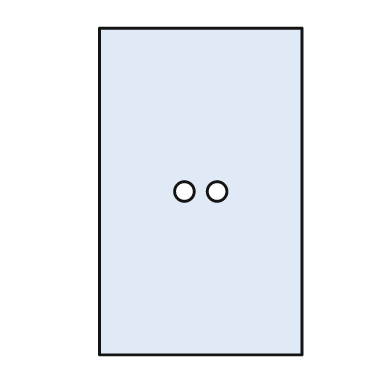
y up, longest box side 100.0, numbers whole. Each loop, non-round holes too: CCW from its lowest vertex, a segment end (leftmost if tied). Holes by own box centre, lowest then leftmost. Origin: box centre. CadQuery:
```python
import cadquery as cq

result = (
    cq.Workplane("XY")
    .moveTo(-31.0, -50.0)
    .lineTo(31.0, -50.0)
    .lineTo(31.0, 50.0)
    .lineTo(-31.0, 50.0)
    .close()
    .moveTo(-5.0, 0.0)
    .circle(3.0)
    .moveTo(5.0, 0.0)
    .circle(3.0)
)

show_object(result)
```